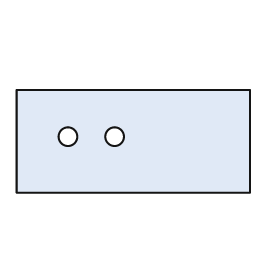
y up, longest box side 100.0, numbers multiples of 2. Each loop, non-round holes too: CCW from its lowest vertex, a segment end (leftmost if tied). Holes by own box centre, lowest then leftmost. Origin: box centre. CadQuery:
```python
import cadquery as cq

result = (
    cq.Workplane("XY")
    .moveTo(-50.0, -22.0)
    .lineTo(50.0, -22.0)
    .lineTo(50.0, 22.0)
    .lineTo(-50.0, 22.0)
    .close()
    .moveTo(-28.0, 2.0)
    .circle(4.0)
    .moveTo(-8.0, 2.0)
    .circle(4.0)
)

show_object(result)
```